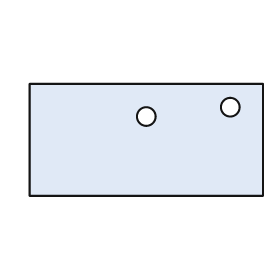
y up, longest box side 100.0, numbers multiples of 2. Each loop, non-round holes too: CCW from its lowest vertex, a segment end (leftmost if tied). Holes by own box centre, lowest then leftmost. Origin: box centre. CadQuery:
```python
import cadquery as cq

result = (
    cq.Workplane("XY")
    .moveTo(-50.0, -24.0)
    .lineTo(50.0, -24.0)
    .lineTo(50.0, 24.0)
    .lineTo(-50.0, 24.0)
    .close()
    .moveTo(0.0, 10.0)
    .circle(4.0)
    .moveTo(36.0, 14.0)
    .circle(4.0)
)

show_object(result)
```